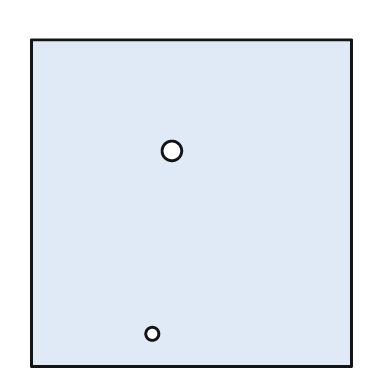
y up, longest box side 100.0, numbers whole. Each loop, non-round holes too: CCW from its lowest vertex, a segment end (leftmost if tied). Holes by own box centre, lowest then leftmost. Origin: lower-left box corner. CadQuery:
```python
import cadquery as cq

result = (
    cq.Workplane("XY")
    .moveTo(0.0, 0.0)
    .lineTo(98.0, 0.0)
    .lineTo(98.0, 100.0)
    .lineTo(0.0, 100.0)
    .close()
    .moveTo(37.0, 10.0)
    .circle(2.0)
    .moveTo(43.0, 66.0)
    .circle(3.0)
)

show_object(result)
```